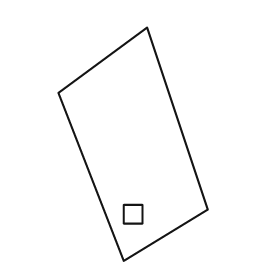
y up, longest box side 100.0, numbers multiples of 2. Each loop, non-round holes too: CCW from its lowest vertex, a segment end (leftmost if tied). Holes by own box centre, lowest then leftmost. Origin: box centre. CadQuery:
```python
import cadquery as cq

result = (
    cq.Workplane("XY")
    .moveTo(-4.0, -50.0)
    .lineTo(32.0, -28.0)
    .lineTo(6.0, 50.0)
    .lineTo(-32.0, 22.0)
    .close()
    .moveTo(-4.0, -34.0)
    .lineTo(4.0, -34.0)
    .lineTo(4.0, -26.0)
    .lineTo(-4.0, -26.0)
    .close()
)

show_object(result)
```